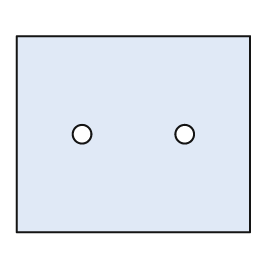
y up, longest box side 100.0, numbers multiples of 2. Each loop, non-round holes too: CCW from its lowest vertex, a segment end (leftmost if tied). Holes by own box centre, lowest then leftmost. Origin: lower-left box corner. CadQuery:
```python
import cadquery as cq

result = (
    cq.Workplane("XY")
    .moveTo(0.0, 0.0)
    .lineTo(100.0, 0.0)
    .lineTo(100.0, 84.0)
    .lineTo(0.0, 84.0)
    .close()
    .moveTo(28.0, 42.0)
    .circle(4.0)
    .moveTo(72.0, 42.0)
    .circle(4.0)
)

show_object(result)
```